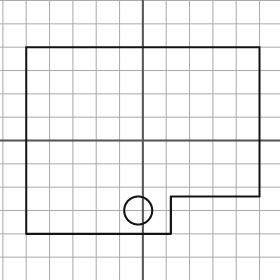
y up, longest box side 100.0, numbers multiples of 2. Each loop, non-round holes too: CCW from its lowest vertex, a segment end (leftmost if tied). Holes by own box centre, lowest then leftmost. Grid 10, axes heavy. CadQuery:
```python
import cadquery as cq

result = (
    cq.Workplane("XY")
    .moveTo(-50.0, -40.0)
    .lineTo(12.0, -40.0)
    .lineTo(12.0, -24.0)
    .lineTo(50.0, -24.0)
    .lineTo(50.0, 40.0)
    .lineTo(-50.0, 40.0)
    .close()
    .moveTo(-2.0, -30.0)
    .circle(6.0)
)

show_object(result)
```